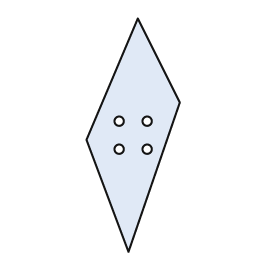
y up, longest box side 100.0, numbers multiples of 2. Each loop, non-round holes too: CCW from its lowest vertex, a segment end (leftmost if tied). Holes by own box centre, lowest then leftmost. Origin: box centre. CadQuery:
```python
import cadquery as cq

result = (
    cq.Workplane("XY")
    .moveTo(-2.0, -50.0)
    .lineTo(20.0, 14.0)
    .lineTo(2.0, 50.0)
    .lineTo(-20.0, -2.0)
    .close()
    .moveTo(-6.0, -6.0)
    .circle(2.0)
    .moveTo(6.0, -6.0)
    .circle(2.0)
    .moveTo(-6.0, 6.0)
    .circle(2.0)
    .moveTo(6.0, 6.0)
    .circle(2.0)
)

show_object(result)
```